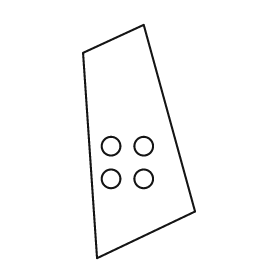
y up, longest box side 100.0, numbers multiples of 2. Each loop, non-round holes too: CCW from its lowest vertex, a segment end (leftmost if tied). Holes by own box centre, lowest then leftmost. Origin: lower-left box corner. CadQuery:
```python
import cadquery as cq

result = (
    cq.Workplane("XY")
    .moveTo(6.0, 0.0)
    .lineTo(48.0, 20.0)
    .lineTo(26.0, 100.0)
    .lineTo(0.0, 88.0)
    .close()
    .moveTo(12.0, 34.0)
    .circle(4.0)
    .moveTo(26.0, 34.0)
    .circle(4.0)
    .moveTo(12.0, 48.0)
    .circle(4.0)
    .moveTo(26.0, 48.0)
    .circle(4.0)
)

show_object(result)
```